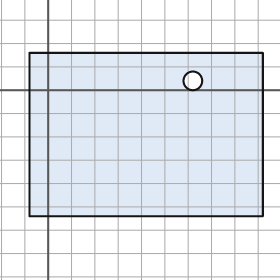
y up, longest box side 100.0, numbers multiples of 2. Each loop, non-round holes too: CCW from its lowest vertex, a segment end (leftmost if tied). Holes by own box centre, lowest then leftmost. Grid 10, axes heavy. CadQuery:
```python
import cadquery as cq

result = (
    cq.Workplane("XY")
    .moveTo(-8.0, -54.0)
    .lineTo(92.0, -54.0)
    .lineTo(92.0, 16.0)
    .lineTo(-8.0, 16.0)
    .close()
    .moveTo(62.0, 4.0)
    .circle(4.0)
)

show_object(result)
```